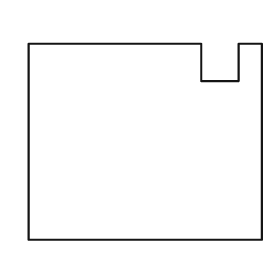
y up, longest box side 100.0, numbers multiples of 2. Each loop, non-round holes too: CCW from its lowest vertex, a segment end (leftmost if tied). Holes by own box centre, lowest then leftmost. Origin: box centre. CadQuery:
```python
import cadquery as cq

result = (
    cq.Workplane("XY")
    .moveTo(-50.0, -42.0)
    .lineTo(50.0, -42.0)
    .lineTo(50.0, 42.0)
    .lineTo(40.0, 42.0)
    .lineTo(40.0, 26.0)
    .lineTo(24.0, 26.0)
    .lineTo(24.0, 42.0)
    .lineTo(-50.0, 42.0)
    .close()
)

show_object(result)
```